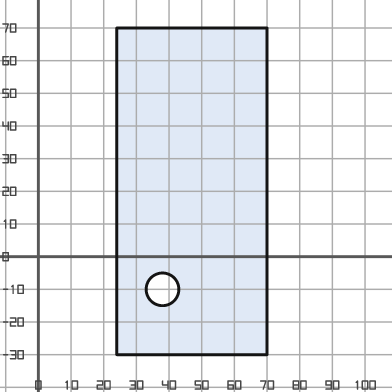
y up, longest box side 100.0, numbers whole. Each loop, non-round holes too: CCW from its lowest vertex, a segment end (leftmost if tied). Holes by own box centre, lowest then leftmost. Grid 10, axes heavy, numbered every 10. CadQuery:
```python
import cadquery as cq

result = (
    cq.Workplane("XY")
    .moveTo(24.0, -30.0)
    .lineTo(70.0, -30.0)
    .lineTo(70.0, 70.0)
    .lineTo(24.0, 70.0)
    .close()
    .moveTo(38.0, -10.0)
    .circle(5.0)
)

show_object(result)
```